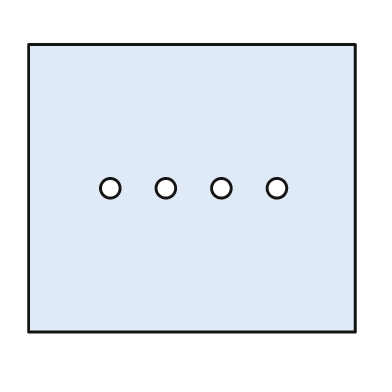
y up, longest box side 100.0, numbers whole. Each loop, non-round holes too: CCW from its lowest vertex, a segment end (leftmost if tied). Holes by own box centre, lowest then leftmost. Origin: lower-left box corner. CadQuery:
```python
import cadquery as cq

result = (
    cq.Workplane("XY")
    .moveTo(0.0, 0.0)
    .lineTo(100.0, 0.0)
    .lineTo(100.0, 88.0)
    .lineTo(0.0, 88.0)
    .close()
    .moveTo(25.0, 44.0)
    .circle(3.0)
    .moveTo(42.0, 44.0)
    .circle(3.0)
    .moveTo(59.0, 44.0)
    .circle(3.0)
    .moveTo(76.0, 44.0)
    .circle(3.0)
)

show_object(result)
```